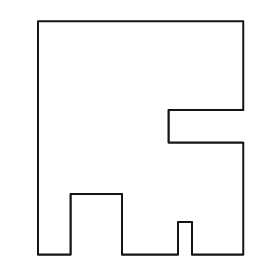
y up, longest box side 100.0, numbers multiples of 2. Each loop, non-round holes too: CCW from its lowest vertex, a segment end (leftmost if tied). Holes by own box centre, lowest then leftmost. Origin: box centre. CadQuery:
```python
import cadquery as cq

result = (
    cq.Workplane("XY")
    .moveTo(-44.0, -50.0)
    .lineTo(-30.0, -50.0)
    .lineTo(-30.0, -24.0)
    .lineTo(-8.0, -24.0)
    .lineTo(-8.0, -50.0)
    .lineTo(16.0, -50.0)
    .lineTo(16.0, -36.0)
    .lineTo(22.0, -36.0)
    .lineTo(22.0, -50.0)
    .lineTo(44.0, -50.0)
    .lineTo(44.0, -2.0)
    .lineTo(12.0, -2.0)
    .lineTo(12.0, 12.0)
    .lineTo(44.0, 12.0)
    .lineTo(44.0, 50.0)
    .lineTo(-44.0, 50.0)
    .close()
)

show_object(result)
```